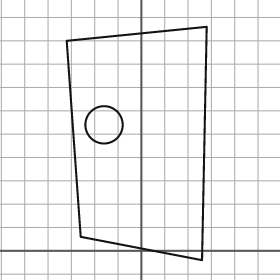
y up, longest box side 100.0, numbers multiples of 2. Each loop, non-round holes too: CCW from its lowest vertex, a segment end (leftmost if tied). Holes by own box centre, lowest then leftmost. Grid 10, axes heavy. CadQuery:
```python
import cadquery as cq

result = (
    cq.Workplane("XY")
    .moveTo(26.0, -4.0)
    .lineTo(28.0, 96.0)
    .lineTo(-32.0, 90.0)
    .lineTo(-26.0, 6.0)
    .close()
    .moveTo(-16.0, 54.0)
    .circle(8.0)
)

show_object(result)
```